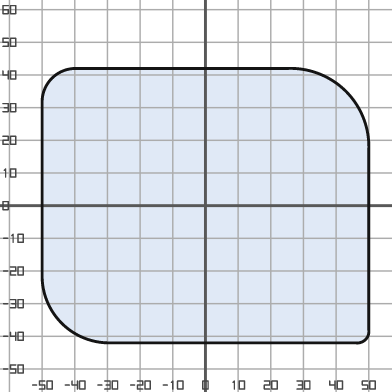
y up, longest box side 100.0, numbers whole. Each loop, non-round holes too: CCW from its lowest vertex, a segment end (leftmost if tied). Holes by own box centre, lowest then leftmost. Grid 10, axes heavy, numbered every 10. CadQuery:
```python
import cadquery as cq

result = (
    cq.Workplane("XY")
    .moveTo(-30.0, -42.0)
    .lineTo(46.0, -42.0)
    .threePointArc((49.0, -41.0), (50.0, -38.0))
    .lineTo(50.0, 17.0)
    .threePointArc((43.0, 35.0), (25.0, 42.0))
    .lineTo(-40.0, 42.0)
    .threePointArc((-47.0, 39.0), (-50.0, 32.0))
    .lineTo(-50.0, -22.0)
    .threePointArc((-44.0, -36.0), (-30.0, -42.0))
    .close()
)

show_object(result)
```